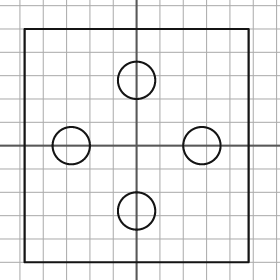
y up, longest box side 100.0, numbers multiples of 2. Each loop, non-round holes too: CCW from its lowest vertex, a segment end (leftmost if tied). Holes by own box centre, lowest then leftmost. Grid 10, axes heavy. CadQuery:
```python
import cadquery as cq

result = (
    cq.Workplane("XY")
    .moveTo(-48.0, -50.0)
    .lineTo(48.0, -50.0)
    .lineTo(48.0, 50.0)
    .lineTo(-48.0, 50.0)
    .close()
    .moveTo(0.0, -28.0)
    .circle(8.0)
    .moveTo(-28.0, 0.0)
    .circle(8.0)
    .moveTo(28.0, 0.0)
    .circle(8.0)
    .moveTo(0.0, 28.0)
    .circle(8.0)
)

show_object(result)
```